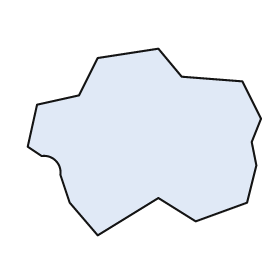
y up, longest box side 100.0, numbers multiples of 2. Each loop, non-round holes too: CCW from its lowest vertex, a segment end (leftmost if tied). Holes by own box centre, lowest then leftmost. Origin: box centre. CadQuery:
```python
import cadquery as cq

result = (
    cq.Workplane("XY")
    .moveTo(-20.0, -40.0)
    .lineTo(6.0, -24.0)
    .lineTo(22.0, -34.0)
    .lineTo(44.0, -26.0)
    .lineTo(48.0, -10.0)
    .lineTo(46.0, 0.0)
    .lineTo(50.0, 10.0)
    .lineTo(42.0, 26.0)
    .lineTo(16.0, 28.0)
    .lineTo(6.0, 40.0)
    .lineTo(-20.0, 36.0)
    .lineTo(-28.0, 20.0)
    .lineTo(-46.0, 16.0)
    .lineTo(-50.0, -2.0)
    .lineTo(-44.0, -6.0)
    .threePointArc((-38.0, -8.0), (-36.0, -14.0))
    .lineTo(-32.0, -26.0)
    .close()
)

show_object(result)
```